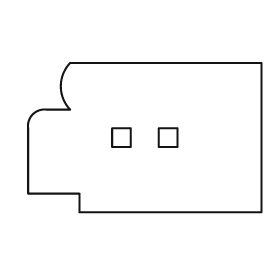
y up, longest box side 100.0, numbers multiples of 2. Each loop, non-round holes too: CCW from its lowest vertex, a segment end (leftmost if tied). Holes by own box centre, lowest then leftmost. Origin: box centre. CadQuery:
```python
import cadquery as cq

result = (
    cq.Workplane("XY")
    .moveTo(-28.0, -32.0)
    .lineTo(50.0, -32.0)
    .lineTo(50.0, 32.0)
    .lineTo(-32.0, 32.0)
    .threePointArc((-36.0, 22.0), (-32.0, 12.0))
    .lineTo(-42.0, 12.0)
    .threePointArc((-48.0, 10.0), (-50.0, 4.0))
    .lineTo(-50.0, -24.0)
    .lineTo(-28.0, -24.0)
    .close()
    .moveTo(-14.0, -4.0)
    .lineTo(-6.0, -4.0)
    .lineTo(-6.0, 4.0)
    .lineTo(-14.0, 4.0)
    .close()
    .moveTo(6.0, -4.0)
    .lineTo(14.0, -4.0)
    .lineTo(14.0, 4.0)
    .lineTo(6.0, 4.0)
    .close()
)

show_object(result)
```